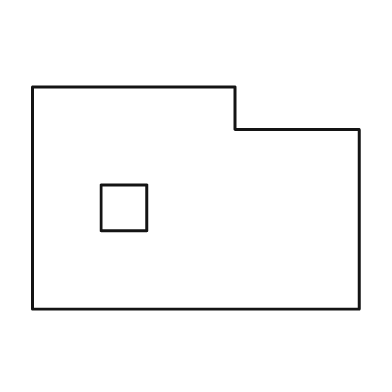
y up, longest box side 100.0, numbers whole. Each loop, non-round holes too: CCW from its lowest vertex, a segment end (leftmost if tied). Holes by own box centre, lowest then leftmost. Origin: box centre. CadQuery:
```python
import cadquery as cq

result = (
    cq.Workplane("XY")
    .moveTo(-50.0, -34.0)
    .lineTo(50.0, -34.0)
    .lineTo(50.0, 21.0)
    .lineTo(12.0, 21.0)
    .lineTo(12.0, 34.0)
    .lineTo(-50.0, 34.0)
    .close()
    .moveTo(-29.0, -10.0)
    .lineTo(-15.0, -10.0)
    .lineTo(-15.0, 4.0)
    .lineTo(-29.0, 4.0)
    .close()
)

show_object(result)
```